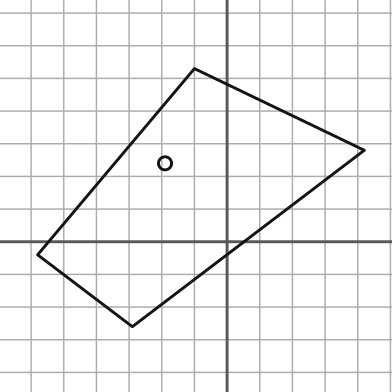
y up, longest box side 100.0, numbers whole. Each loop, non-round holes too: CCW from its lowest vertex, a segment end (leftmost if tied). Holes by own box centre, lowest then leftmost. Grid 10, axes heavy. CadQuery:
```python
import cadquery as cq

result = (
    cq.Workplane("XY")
    .moveTo(-29.0, -26.0)
    .lineTo(42.0, 28.0)
    .lineTo(-10.0, 53.0)
    .lineTo(-58.0, -4.0)
    .close()
    .moveTo(-19.0, 24.0)
    .circle(2.0)
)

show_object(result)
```